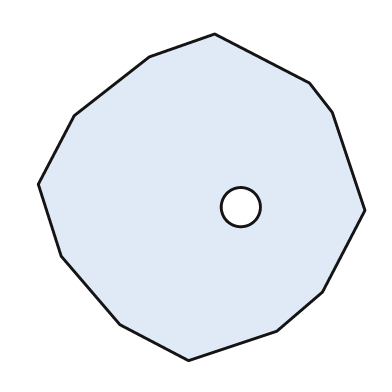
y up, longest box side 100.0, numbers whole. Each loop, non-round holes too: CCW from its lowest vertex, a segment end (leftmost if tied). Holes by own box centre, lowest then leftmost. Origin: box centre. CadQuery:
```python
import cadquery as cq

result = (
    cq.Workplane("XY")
    .moveTo(-4.0, -50.0)
    .lineTo(23.0, -41.0)
    .lineTo(37.0, -29.0)
    .lineTo(50.0, -4.0)
    .lineTo(40.0, 26.0)
    .lineTo(33.0, 35.0)
    .lineTo(4.0, 50.0)
    .lineTo(-16.0, 43.0)
    .lineTo(-39.0, 25.0)
    .lineTo(-50.0, 4.0)
    .lineTo(-43.0, -18.0)
    .lineTo(-25.0, -39.0)
    .close()
    .moveTo(12.0, -3.0)
    .circle(6.0)
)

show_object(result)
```